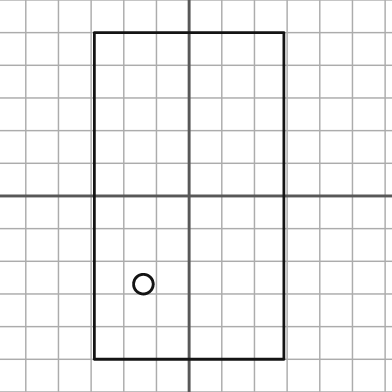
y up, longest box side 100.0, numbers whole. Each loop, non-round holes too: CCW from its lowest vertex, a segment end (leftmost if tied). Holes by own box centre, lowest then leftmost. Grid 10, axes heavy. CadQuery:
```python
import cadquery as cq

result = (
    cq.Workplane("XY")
    .moveTo(-29.0, -50.0)
    .lineTo(29.0, -50.0)
    .lineTo(29.0, 50.0)
    .lineTo(-29.0, 50.0)
    .close()
    .moveTo(-14.0, -27.0)
    .circle(3.0)
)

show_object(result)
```